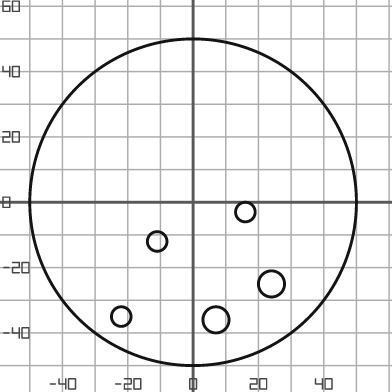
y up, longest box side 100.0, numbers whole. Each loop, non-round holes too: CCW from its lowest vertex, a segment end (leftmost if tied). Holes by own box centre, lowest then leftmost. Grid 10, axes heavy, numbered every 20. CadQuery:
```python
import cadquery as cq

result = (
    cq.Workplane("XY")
    .moveTo(0.0, 0.0)
    .circle(50.0)
    .moveTo(7.0, -36.0)
    .circle(4.0)
    .moveTo(-22.0, -35.0)
    .circle(3.0)
    .moveTo(24.0, -25.0)
    .circle(4.0)
    .moveTo(-11.0, -12.0)
    .circle(3.0)
    .moveTo(16.0, -3.0)
    .circle(3.0)
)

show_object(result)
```